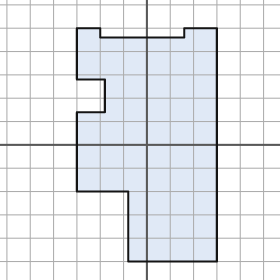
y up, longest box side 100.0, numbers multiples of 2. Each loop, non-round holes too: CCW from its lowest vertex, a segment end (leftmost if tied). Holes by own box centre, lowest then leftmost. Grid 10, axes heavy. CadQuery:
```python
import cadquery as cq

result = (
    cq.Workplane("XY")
    .moveTo(-8.0, -50.0)
    .lineTo(30.0, -50.0)
    .lineTo(30.0, 50.0)
    .lineTo(16.0, 50.0)
    .lineTo(16.0, 46.0)
    .lineTo(-20.0, 46.0)
    .lineTo(-20.0, 50.0)
    .lineTo(-30.0, 50.0)
    .lineTo(-30.0, 28.0)
    .lineTo(-18.0, 28.0)
    .lineTo(-18.0, 14.0)
    .lineTo(-30.0, 14.0)
    .lineTo(-30.0, -20.0)
    .lineTo(-8.0, -20.0)
    .close()
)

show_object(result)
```